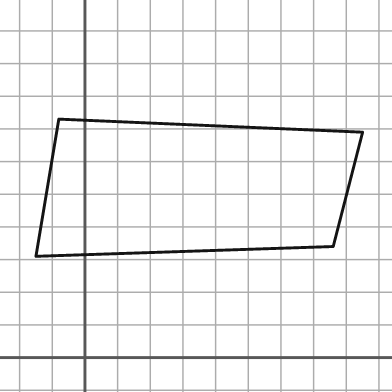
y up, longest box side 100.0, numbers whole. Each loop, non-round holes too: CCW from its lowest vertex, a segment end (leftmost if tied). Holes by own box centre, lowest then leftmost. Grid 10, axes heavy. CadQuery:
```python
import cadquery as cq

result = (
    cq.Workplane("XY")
    .moveTo(-15.0, 31.0)
    .lineTo(76.0, 34.0)
    .lineTo(85.0, 69.0)
    .lineTo(-8.0, 73.0)
    .close()
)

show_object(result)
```